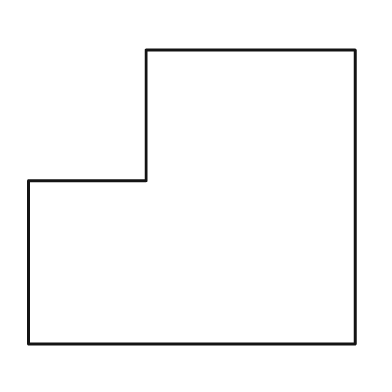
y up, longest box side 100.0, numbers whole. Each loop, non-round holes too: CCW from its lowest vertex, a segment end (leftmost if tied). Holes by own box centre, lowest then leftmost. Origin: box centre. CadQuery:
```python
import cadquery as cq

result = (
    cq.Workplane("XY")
    .moveTo(-50.0, -45.0)
    .lineTo(50.0, -45.0)
    .lineTo(50.0, 45.0)
    .lineTo(-14.0, 45.0)
    .lineTo(-14.0, 5.0)
    .lineTo(-50.0, 5.0)
    .close()
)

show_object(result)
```